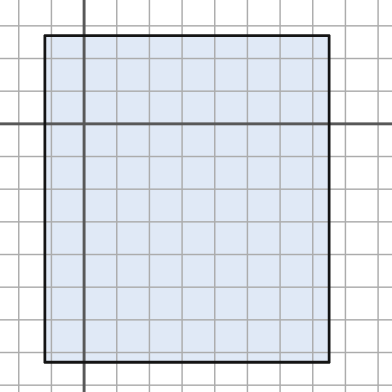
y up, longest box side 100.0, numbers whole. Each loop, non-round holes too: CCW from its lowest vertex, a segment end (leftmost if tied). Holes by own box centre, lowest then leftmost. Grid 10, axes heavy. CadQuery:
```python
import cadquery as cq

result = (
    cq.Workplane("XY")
    .moveTo(-12.0, -73.0)
    .lineTo(75.0, -73.0)
    .lineTo(75.0, 27.0)
    .lineTo(-12.0, 27.0)
    .close()
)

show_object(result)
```